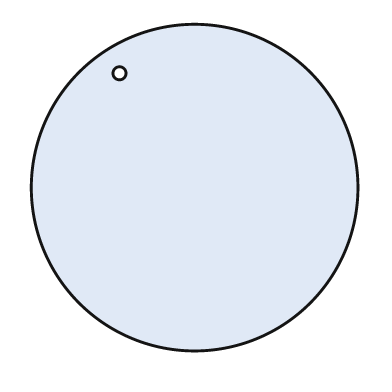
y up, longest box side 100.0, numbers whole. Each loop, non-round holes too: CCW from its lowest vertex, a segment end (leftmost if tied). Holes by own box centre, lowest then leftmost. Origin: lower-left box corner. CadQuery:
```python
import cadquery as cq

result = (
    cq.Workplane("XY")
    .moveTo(50.0, 50.0)
    .circle(50.0)
    .moveTo(27.0, 85.0)
    .circle(2.0)
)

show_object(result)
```